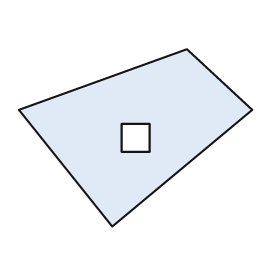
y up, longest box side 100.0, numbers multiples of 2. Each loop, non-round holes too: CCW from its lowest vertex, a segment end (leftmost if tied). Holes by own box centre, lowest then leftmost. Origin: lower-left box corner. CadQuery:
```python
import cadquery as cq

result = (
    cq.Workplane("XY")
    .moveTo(40.0, 0.0)
    .lineTo(100.0, 50.0)
    .lineTo(72.0, 76.0)
    .lineTo(0.0, 50.0)
    .close()
    .moveTo(44.0, 32.0)
    .lineTo(56.0, 32.0)
    .lineTo(56.0, 44.0)
    .lineTo(44.0, 44.0)
    .close()
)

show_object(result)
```